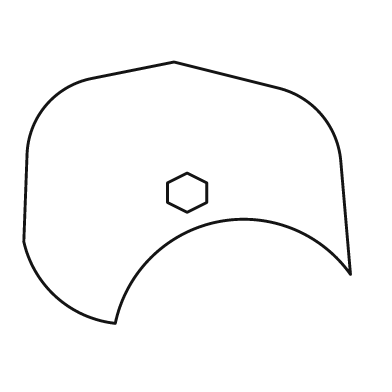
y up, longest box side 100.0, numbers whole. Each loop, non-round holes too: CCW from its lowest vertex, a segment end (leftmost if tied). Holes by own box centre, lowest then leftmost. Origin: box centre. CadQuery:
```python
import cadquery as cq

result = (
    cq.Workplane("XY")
    .moveTo(-22.0, -40.0)
    .threePointArc((9.0, -9.0), (50.0, -25.0))
    .lineTo(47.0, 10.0)
    .threePointArc((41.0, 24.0), (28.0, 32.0))
    .lineTo(-4.0, 40.0)
    .lineTo(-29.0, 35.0)
    .threePointArc((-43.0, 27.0), (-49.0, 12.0))
    .lineTo(-50.0, -15.0)
    .threePointArc((-40.0, -32.0), (-22.0, -40.0))
    .close()
    .moveTo(0.0, -6.0)
    .lineTo(6.0, -3.0)
    .lineTo(6.0, 3.0)
    .lineTo(0.0, 6.0)
    .lineTo(-6.0, 3.0)
    .lineTo(-6.0, -3.0)
    .close()
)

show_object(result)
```